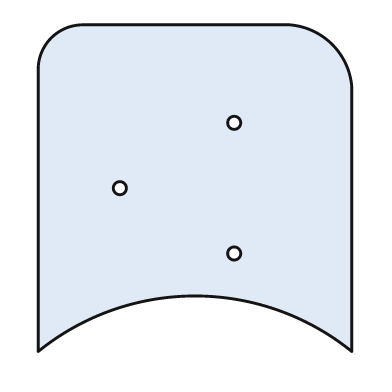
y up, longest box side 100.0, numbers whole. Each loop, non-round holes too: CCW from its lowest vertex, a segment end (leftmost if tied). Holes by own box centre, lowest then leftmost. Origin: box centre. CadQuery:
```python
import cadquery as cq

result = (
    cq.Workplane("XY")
    .moveTo(-48.0, -50.0)
    .threePointArc((0.0, -33.0), (48.0, -50.0))
    .lineTo(48.0, 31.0)
    .threePointArc((42.0, 44.0), (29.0, 50.0))
    .lineTo(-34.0, 50.0)
    .threePointArc((-44.0, 46.0), (-48.0, 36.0))
    .close()
    .moveTo(12.0, -20.0)
    .circle(2.0)
    .moveTo(-23.0, 0.0)
    .circle(2.0)
    .moveTo(12.0, 20.0)
    .circle(2.0)
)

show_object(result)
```